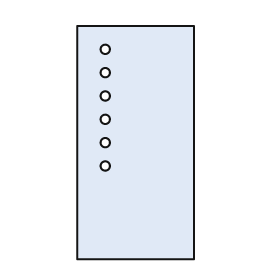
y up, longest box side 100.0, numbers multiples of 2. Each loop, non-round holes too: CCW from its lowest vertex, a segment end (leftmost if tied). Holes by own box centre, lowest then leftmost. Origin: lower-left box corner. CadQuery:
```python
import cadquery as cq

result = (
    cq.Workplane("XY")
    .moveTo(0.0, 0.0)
    .lineTo(50.0, 0.0)
    .lineTo(50.0, 100.0)
    .lineTo(0.0, 100.0)
    .close()
    .moveTo(12.0, 40.0)
    .circle(2.0)
    .moveTo(12.0, 50.0)
    .circle(2.0)
    .moveTo(12.0, 60.0)
    .circle(2.0)
    .moveTo(12.0, 70.0)
    .circle(2.0)
    .moveTo(12.0, 80.0)
    .circle(2.0)
    .moveTo(12.0, 90.0)
    .circle(2.0)
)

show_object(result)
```